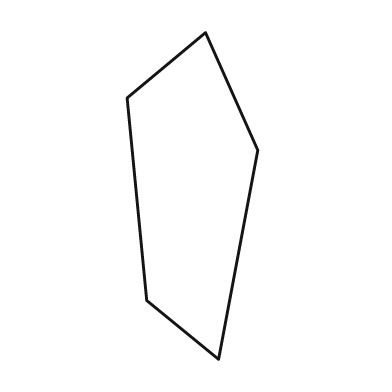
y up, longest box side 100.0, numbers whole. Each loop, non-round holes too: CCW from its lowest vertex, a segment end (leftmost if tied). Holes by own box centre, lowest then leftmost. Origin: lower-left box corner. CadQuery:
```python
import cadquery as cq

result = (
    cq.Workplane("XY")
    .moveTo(28.0, 0.0)
    .lineTo(40.0, 64.0)
    .lineTo(24.0, 100.0)
    .lineTo(0.0, 80.0)
    .lineTo(6.0, 18.0)
    .close()
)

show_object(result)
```